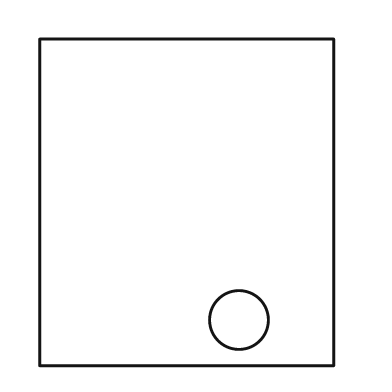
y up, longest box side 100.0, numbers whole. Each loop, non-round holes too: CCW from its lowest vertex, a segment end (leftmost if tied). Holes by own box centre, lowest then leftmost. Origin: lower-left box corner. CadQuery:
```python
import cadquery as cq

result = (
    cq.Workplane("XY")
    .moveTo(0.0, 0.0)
    .lineTo(90.0, 0.0)
    .lineTo(90.0, 100.0)
    .lineTo(0.0, 100.0)
    .close()
    .moveTo(61.0, 14.0)
    .circle(9.0)
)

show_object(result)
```